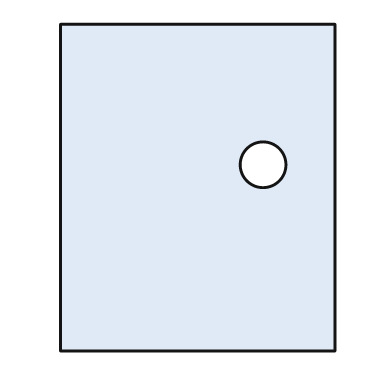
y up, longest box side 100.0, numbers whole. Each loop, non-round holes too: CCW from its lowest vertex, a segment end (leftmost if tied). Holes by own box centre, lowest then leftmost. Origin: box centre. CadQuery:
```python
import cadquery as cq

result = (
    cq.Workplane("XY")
    .moveTo(-42.0, -50.0)
    .lineTo(42.0, -50.0)
    .lineTo(42.0, 50.0)
    .lineTo(-42.0, 50.0)
    .close()
    .moveTo(20.0, 7.0)
    .circle(7.0)
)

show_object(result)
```